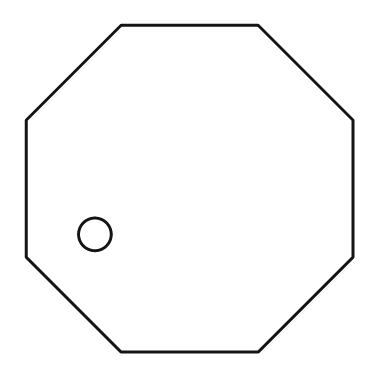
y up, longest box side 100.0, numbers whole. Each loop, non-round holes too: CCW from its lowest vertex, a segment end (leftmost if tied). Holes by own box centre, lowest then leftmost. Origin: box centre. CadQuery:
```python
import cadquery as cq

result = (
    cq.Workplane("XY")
    .moveTo(-21.0, -50.0)
    .lineTo(21.0, -50.0)
    .lineTo(50.0, -21.0)
    .lineTo(50.0, 21.0)
    .lineTo(21.0, 50.0)
    .lineTo(-21.0, 50.0)
    .lineTo(-50.0, 21.0)
    .lineTo(-50.0, -21.0)
    .close()
    .moveTo(-29.0, -14.0)
    .circle(5.0)
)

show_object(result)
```